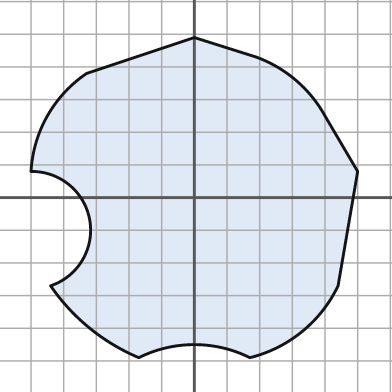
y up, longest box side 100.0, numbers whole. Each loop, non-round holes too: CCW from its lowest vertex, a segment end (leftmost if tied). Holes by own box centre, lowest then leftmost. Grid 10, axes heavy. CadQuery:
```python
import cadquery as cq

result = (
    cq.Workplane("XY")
    .moveTo(-17.0, -49.0)
    .threePointArc((0.0, -45.0), (17.0, -49.0))
    .threePointArc((33.0, -41.0), (44.0, -27.0))
    .lineTo(50.0, 8.0)
    .lineTo(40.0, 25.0)
    .threePointArc((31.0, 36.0), (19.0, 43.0))
    .lineTo(0.0, 49.0)
    .lineTo(-33.0, 38.0)
    .threePointArc((-45.0, 25.0), (-50.0, 8.0))
    .threePointArc((-32.0, -7.0), (-44.0, -27.0))
    .threePointArc((-32.0, -40.0), (-17.0, -49.0))
    .close()
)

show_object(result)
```